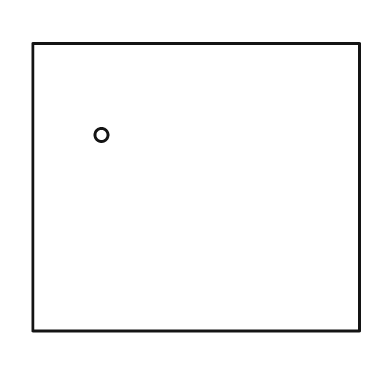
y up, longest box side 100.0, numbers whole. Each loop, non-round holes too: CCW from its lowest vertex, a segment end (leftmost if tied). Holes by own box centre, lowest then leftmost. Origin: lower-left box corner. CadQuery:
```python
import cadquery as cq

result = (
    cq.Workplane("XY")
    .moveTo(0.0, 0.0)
    .lineTo(100.0, 0.0)
    .lineTo(100.0, 88.0)
    .lineTo(0.0, 88.0)
    .close()
    .moveTo(21.0, 60.0)
    .circle(2.0)
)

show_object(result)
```